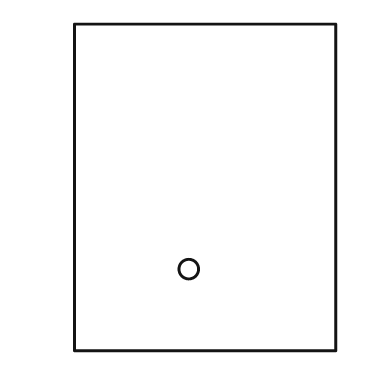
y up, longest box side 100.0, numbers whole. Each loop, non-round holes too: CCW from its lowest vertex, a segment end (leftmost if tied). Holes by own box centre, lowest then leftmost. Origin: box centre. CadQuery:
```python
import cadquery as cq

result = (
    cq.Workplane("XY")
    .moveTo(-40.0, -50.0)
    .lineTo(40.0, -50.0)
    .lineTo(40.0, 50.0)
    .lineTo(-40.0, 50.0)
    .close()
    .moveTo(-5.0, -25.0)
    .circle(3.0)
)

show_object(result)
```